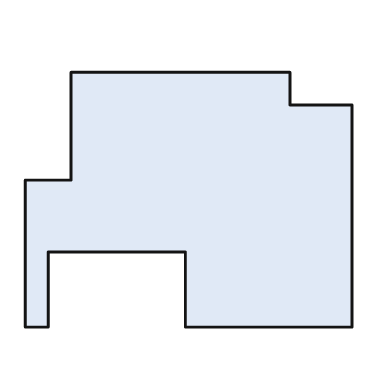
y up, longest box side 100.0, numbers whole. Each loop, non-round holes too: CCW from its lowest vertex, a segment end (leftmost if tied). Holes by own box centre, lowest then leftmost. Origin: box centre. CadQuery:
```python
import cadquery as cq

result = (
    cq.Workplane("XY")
    .moveTo(-50.0, -39.0)
    .lineTo(-43.0, -39.0)
    .lineTo(-43.0, -16.0)
    .lineTo(-1.0, -16.0)
    .lineTo(-1.0, -39.0)
    .lineTo(50.0, -39.0)
    .lineTo(50.0, 29.0)
    .lineTo(31.0, 29.0)
    .lineTo(31.0, 39.0)
    .lineTo(-36.0, 39.0)
    .lineTo(-36.0, 6.0)
    .lineTo(-50.0, 6.0)
    .close()
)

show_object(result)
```